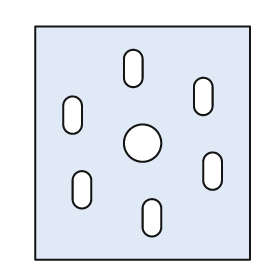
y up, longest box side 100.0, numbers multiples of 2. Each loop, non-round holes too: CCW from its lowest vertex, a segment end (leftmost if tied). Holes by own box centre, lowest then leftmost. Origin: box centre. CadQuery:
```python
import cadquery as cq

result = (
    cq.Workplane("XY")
    .moveTo(-46.0, -50.0)
    .lineTo(46.0, -50.0)
    .lineTo(46.0, 50.0)
    .lineTo(-46.0, 50.0)
    .close()
    .moveTo(0.0, -36.0)
    .threePointArc((4.0, -40.0), (8.0, -36.0))
    .lineTo(8.0, -28.0)
    .threePointArc((4.0, -24.0), (0.0, -28.0))
    .close()
    .moveTo(-30.0, -24.0)
    .threePointArc((-26.0, -28.0), (-22.0, -24.0))
    .lineTo(-22.0, -16.0)
    .threePointArc((-26.0, -12.0), (-30.0, -16.0))
    .close()
    .moveTo(26.0, -16.0)
    .threePointArc((30.0, -20.0), (34.0, -16.0))
    .lineTo(34.0, -8.0)
    .threePointArc((30.0, -4.0), (26.0, -8.0))
    .close()
    .moveTo(0.0, 0.0)
    .circle(8.0)
    .moveTo(-34.0, 8.0)
    .threePointArc((-30.0, 4.0), (-26.0, 8.0))
    .lineTo(-26.0, 16.0)
    .threePointArc((-30.0, 20.0), (-34.0, 16.0))
    .close()
    .moveTo(22.0, 16.0)
    .threePointArc((26.0, 12.0), (30.0, 16.0))
    .lineTo(30.0, 24.0)
    .threePointArc((26.0, 28.0), (22.0, 24.0))
    .close()
    .moveTo(-8.0, 28.0)
    .threePointArc((-4.0, 24.0), (0.0, 28.0))
    .lineTo(0.0, 36.0)
    .threePointArc((-4.0, 40.0), (-8.0, 36.0))
    .close()
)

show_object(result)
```